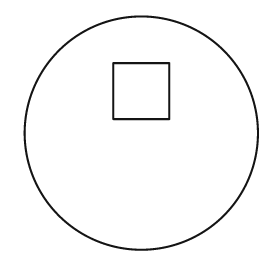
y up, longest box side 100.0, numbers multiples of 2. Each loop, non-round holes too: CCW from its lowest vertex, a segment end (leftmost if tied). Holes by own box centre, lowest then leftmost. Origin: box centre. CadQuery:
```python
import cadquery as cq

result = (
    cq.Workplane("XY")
    .moveTo(0.0, 0.0)
    .circle(50.0)
    .moveTo(-12.0, 6.0)
    .lineTo(12.0, 6.0)
    .lineTo(12.0, 30.0)
    .lineTo(-12.0, 30.0)
    .close()
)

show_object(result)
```